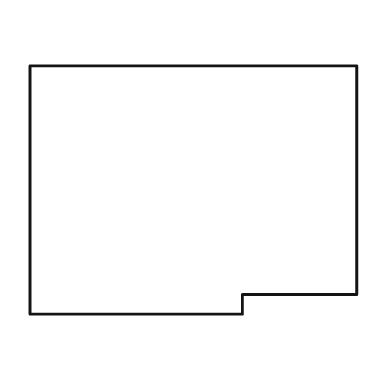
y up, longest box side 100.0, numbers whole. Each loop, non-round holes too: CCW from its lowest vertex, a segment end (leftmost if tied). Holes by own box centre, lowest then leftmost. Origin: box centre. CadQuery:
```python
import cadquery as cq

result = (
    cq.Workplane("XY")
    .moveTo(-50.0, -38.0)
    .lineTo(15.0, -38.0)
    .lineTo(15.0, -32.0)
    .lineTo(50.0, -32.0)
    .lineTo(50.0, 38.0)
    .lineTo(-50.0, 38.0)
    .close()
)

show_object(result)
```